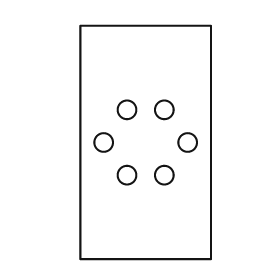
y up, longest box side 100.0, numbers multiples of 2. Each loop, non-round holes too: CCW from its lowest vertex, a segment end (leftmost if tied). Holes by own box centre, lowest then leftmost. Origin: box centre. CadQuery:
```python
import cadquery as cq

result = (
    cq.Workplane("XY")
    .moveTo(-28.0, -50.0)
    .lineTo(28.0, -50.0)
    .lineTo(28.0, 50.0)
    .lineTo(-28.0, 50.0)
    .close()
    .moveTo(-8.0, -14.0)
    .circle(4.0)
    .moveTo(8.0, -14.0)
    .circle(4.0)
    .moveTo(-18.0, 0.0)
    .circle(4.0)
    .moveTo(18.0, 0.0)
    .circle(4.0)
    .moveTo(-8.0, 14.0)
    .circle(4.0)
    .moveTo(8.0, 14.0)
    .circle(4.0)
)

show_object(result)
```